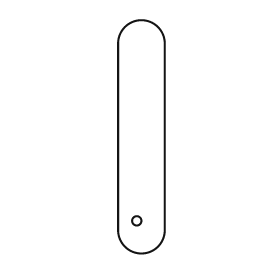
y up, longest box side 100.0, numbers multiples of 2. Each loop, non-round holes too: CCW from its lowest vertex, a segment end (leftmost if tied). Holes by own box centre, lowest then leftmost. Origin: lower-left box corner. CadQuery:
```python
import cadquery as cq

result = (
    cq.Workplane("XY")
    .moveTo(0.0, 10.0)
    .threePointArc((10.0, 0.0), (20.0, 10.0))
    .lineTo(20.0, 90.0)
    .threePointArc((10.0, 100.0), (0.0, 90.0))
    .close()
    .moveTo(8.0, 14.0)
    .circle(2.0)
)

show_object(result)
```